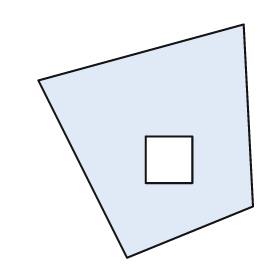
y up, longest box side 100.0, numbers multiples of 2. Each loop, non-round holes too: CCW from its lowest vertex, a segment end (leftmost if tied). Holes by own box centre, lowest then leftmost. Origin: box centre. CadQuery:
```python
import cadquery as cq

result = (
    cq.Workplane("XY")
    .moveTo(-8.0, -50.0)
    .lineTo(46.0, -28.0)
    .lineTo(42.0, 50.0)
    .lineTo(-46.0, 26.0)
    .close()
    .moveTo(0.0, -18.0)
    .lineTo(20.0, -18.0)
    .lineTo(20.0, 2.0)
    .lineTo(0.0, 2.0)
    .close()
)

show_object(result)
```